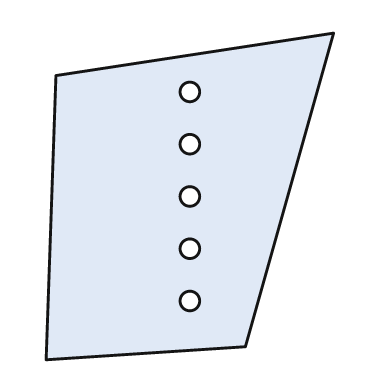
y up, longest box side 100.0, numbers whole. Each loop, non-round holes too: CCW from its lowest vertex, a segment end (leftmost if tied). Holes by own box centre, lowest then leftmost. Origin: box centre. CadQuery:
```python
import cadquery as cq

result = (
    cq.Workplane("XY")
    .moveTo(-44.0, -50.0)
    .lineTo(17.0, -46.0)
    .lineTo(44.0, 50.0)
    .lineTo(-41.0, 37.0)
    .close()
    .moveTo(0.0, -32.0)
    .circle(3.0)
    .moveTo(0.0, -16.0)
    .circle(3.0)
    .moveTo(0.0, 0.0)
    .circle(3.0)
    .moveTo(0.0, 16.0)
    .circle(3.0)
    .moveTo(0.0, 32.0)
    .circle(3.0)
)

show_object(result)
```